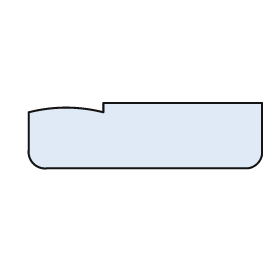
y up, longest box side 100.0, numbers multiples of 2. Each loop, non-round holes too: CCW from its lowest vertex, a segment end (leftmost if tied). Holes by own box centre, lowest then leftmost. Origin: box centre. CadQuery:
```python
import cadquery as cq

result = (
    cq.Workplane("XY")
    .moveTo(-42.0, -14.0)
    .lineTo(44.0, -14.0)
    .threePointArc((48.0, -12.0), (50.0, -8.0))
    .lineTo(50.0, 14.0)
    .lineTo(-18.0, 14.0)
    .lineTo(-18.0, 10.0)
    .threePointArc((-34.0, 12.0), (-50.0, 10.0))
    .lineTo(-50.0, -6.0)
    .threePointArc((-48.0, -12.0), (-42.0, -14.0))
    .close()
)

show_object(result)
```